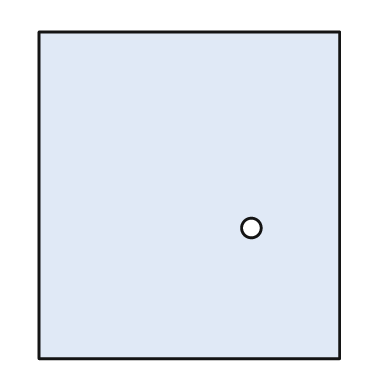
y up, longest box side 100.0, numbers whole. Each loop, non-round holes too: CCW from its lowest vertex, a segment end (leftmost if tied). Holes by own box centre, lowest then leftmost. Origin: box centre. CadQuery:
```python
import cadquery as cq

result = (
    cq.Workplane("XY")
    .moveTo(-46.0, -50.0)
    .lineTo(46.0, -50.0)
    .lineTo(46.0, 50.0)
    .lineTo(-46.0, 50.0)
    .close()
    .moveTo(19.0, -10.0)
    .circle(3.0)
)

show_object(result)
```